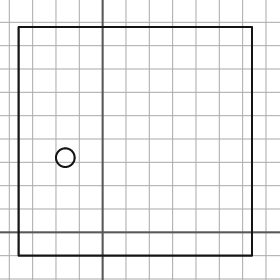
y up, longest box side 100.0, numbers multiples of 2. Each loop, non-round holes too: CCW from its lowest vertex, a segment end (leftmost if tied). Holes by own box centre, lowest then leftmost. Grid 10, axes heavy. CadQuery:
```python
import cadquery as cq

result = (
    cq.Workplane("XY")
    .moveTo(-36.0, -10.0)
    .lineTo(64.0, -10.0)
    .lineTo(64.0, 88.0)
    .lineTo(-36.0, 88.0)
    .close()
    .moveTo(-16.0, 32.0)
    .circle(4.0)
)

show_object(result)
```